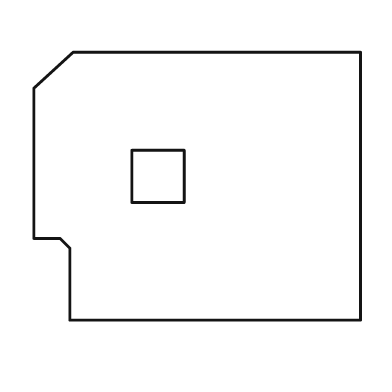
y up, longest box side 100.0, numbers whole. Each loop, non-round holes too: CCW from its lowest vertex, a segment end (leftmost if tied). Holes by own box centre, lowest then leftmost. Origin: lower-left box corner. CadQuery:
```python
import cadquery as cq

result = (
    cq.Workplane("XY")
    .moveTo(11.0, 0.0)
    .lineTo(100.0, 0.0)
    .lineTo(100.0, 82.0)
    .lineTo(12.0, 82.0)
    .lineTo(0.0, 71.0)
    .lineTo(0.0, 25.0)
    .lineTo(8.0, 25.0)
    .lineTo(11.0, 22.0)
    .close()
    .moveTo(30.0, 36.0)
    .lineTo(46.0, 36.0)
    .lineTo(46.0, 52.0)
    .lineTo(30.0, 52.0)
    .close()
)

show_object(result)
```